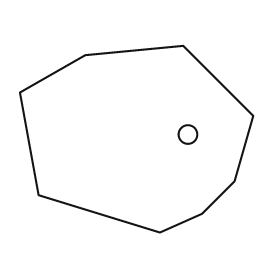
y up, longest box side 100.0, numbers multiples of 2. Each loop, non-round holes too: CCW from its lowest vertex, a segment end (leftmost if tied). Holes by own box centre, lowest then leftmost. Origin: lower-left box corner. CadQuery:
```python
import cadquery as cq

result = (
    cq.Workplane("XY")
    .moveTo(60.0, 0.0)
    .lineTo(78.0, 8.0)
    .lineTo(92.0, 22.0)
    .lineTo(100.0, 50.0)
    .lineTo(70.0, 80.0)
    .lineTo(28.0, 76.0)
    .lineTo(0.0, 60.0)
    .lineTo(8.0, 16.0)
    .close()
    .moveTo(72.0, 42.0)
    .circle(4.0)
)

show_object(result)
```